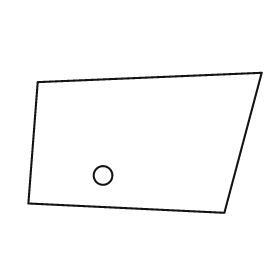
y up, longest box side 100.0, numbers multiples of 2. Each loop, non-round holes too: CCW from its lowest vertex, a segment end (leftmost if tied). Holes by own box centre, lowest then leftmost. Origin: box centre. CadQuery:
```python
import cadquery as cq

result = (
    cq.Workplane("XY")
    .moveTo(34.0, -30.0)
    .lineTo(50.0, 30.0)
    .lineTo(-46.0, 26.0)
    .lineTo(-50.0, -26.0)
    .close()
    .moveTo(-18.0, -14.0)
    .circle(4.0)
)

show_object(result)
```